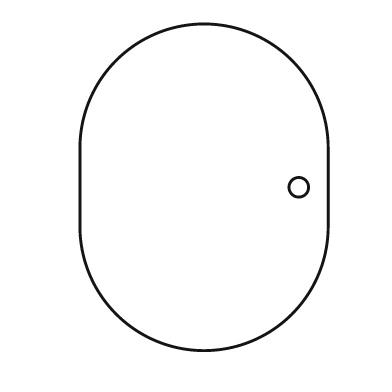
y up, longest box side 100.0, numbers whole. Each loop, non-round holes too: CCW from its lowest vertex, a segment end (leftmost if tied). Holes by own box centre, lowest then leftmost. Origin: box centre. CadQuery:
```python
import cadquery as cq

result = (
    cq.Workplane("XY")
    .moveTo(-38.0, -12.0)
    .threePointArc((0.0, -50.0), (38.0, -12.0))
    .lineTo(38.0, 12.0)
    .threePointArc((0.0, 50.0), (-38.0, 12.0))
    .close()
    .moveTo(29.0, 0.0)
    .circle(3.0)
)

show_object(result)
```